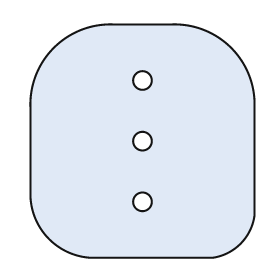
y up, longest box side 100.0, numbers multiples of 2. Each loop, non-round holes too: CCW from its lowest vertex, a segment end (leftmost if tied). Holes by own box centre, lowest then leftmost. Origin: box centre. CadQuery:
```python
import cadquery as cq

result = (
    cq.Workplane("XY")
    .moveTo(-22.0, -50.0)
    .lineTo(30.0, -50.0)
    .threePointArc((42.0, -44.0), (48.0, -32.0))
    .lineTo(48.0, 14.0)
    .threePointArc((38.0, 40.0), (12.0, 50.0))
    .lineTo(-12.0, 50.0)
    .threePointArc((-38.0, 40.0), (-48.0, 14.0))
    .lineTo(-48.0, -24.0)
    .threePointArc((-40.0, -42.0), (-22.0, -50.0))
    .close()
    .moveTo(0.0, -26.0)
    .circle(4.0)
    .moveTo(0.0, 0.0)
    .circle(4.0)
    .moveTo(0.0, 26.0)
    .circle(4.0)
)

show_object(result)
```